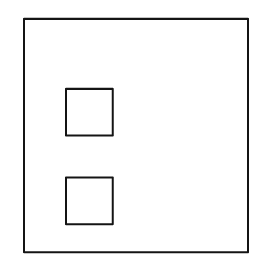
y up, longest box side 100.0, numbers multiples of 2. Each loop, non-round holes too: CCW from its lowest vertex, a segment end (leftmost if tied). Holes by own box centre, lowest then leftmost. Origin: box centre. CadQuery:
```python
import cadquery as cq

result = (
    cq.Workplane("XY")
    .moveTo(-48.0, -50.0)
    .lineTo(48.0, -50.0)
    .lineTo(48.0, 50.0)
    .lineTo(-48.0, 50.0)
    .close()
    .moveTo(-30.0, -38.0)
    .lineTo(-10.0, -38.0)
    .lineTo(-10.0, -18.0)
    .lineTo(-30.0, -18.0)
    .close()
    .moveTo(-30.0, 0.0)
    .lineTo(-10.0, 0.0)
    .lineTo(-10.0, 20.0)
    .lineTo(-30.0, 20.0)
    .close()
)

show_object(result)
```